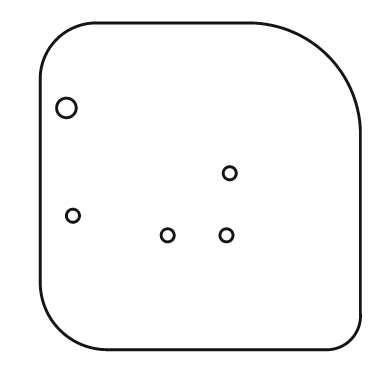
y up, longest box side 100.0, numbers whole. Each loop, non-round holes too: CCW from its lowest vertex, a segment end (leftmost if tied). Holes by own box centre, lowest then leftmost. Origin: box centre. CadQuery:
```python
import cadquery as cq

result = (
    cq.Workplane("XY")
    .moveTo(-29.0, -50.0)
    .lineTo(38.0, -50.0)
    .threePointArc((46.0, -47.0), (49.0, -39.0))
    .lineTo(49.0, 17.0)
    .threePointArc((39.0, 40.0), (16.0, 50.0))
    .lineTo(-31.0, 50.0)
    .threePointArc((-44.0, 45.0), (-49.0, 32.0))
    .lineTo(-49.0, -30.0)
    .threePointArc((-43.0, -44.0), (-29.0, -50.0))
    .close()
    .moveTo(-10.0, -15.0)
    .circle(2.0)
    .moveTo(8.0, -15.0)
    .circle(2.0)
    .moveTo(-39.0, -9.0)
    .circle(2.0)
    .moveTo(9.0, 4.0)
    .circle(2.0)
    .moveTo(-41.0, 24.0)
    .circle(3.0)
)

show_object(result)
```